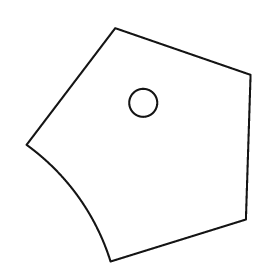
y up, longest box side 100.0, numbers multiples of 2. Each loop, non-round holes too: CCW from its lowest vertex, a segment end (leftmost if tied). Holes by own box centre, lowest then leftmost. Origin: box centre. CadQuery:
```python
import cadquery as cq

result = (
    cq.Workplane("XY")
    .moveTo(-12.0, -50.0)
    .lineTo(46.0, -32.0)
    .lineTo(48.0, 30.0)
    .lineTo(-10.0, 50.0)
    .lineTo(-48.0, 0.0)
    .threePointArc((-26.0, -22.0), (-12.0, -50.0))
    .close()
    .moveTo(2.0, 18.0)
    .circle(6.0)
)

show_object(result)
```